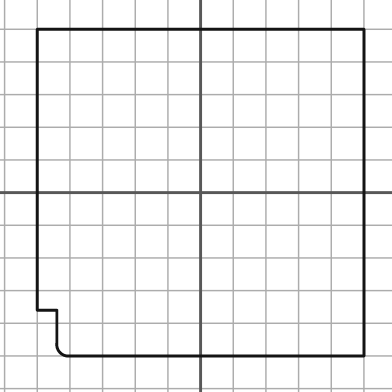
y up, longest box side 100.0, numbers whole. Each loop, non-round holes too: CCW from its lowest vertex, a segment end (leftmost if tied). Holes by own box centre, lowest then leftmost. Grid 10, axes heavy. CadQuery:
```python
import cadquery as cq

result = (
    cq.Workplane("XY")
    .moveTo(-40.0, -50.0)
    .lineTo(50.0, -50.0)
    .lineTo(50.0, 50.0)
    .lineTo(-50.0, 50.0)
    .lineTo(-50.0, -36.0)
    .lineTo(-44.0, -36.0)
    .lineTo(-44.0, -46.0)
    .threePointArc((-43.0, -49.0), (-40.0, -50.0))
    .close()
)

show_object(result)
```